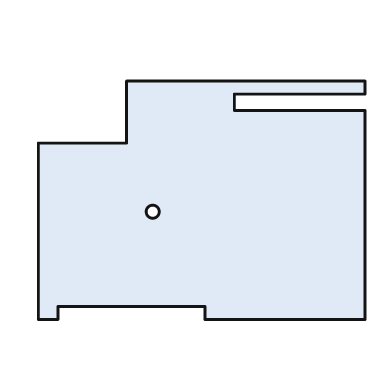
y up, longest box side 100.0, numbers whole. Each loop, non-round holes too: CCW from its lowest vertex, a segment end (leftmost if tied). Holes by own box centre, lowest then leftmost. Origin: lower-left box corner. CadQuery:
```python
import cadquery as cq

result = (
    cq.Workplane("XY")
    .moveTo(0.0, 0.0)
    .lineTo(6.0, 0.0)
    .lineTo(6.0, 4.0)
    .lineTo(51.0, 4.0)
    .lineTo(51.0, 0.0)
    .lineTo(100.0, 0.0)
    .lineTo(100.0, 64.0)
    .lineTo(60.0, 64.0)
    .lineTo(60.0, 69.0)
    .lineTo(100.0, 69.0)
    .lineTo(100.0, 73.0)
    .lineTo(27.0, 73.0)
    .lineTo(27.0, 54.0)
    .lineTo(0.0, 54.0)
    .close()
    .moveTo(35.0, 33.0)
    .circle(2.0)
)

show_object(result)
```